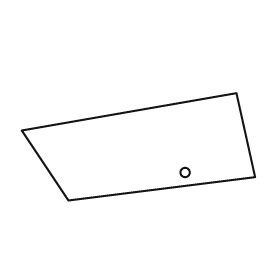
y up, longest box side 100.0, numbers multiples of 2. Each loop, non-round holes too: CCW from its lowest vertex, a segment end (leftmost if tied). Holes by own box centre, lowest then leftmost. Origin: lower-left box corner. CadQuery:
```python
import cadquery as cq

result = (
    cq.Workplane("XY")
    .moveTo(20.0, 0.0)
    .lineTo(100.0, 10.0)
    .lineTo(92.0, 46.0)
    .lineTo(0.0, 30.0)
    .close()
    .moveTo(70.0, 12.0)
    .circle(2.0)
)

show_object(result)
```